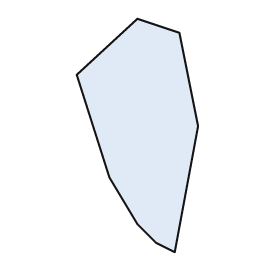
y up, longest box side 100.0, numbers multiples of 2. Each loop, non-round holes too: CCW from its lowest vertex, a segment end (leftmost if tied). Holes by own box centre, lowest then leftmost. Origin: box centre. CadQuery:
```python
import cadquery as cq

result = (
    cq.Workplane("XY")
    .moveTo(16.0, -50.0)
    .lineTo(26.0, 4.0)
    .lineTo(18.0, 44.0)
    .lineTo(0.0, 50.0)
    .lineTo(-26.0, 26.0)
    .lineTo(-12.0, -18.0)
    .lineTo(0.0, -38.0)
    .lineTo(8.0, -46.0)
    .close()
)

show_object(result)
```